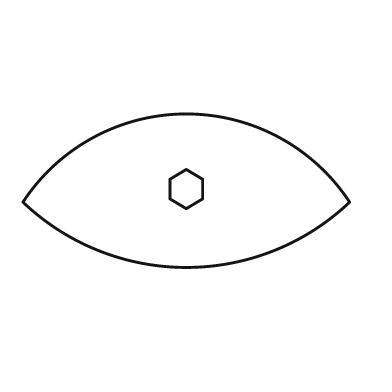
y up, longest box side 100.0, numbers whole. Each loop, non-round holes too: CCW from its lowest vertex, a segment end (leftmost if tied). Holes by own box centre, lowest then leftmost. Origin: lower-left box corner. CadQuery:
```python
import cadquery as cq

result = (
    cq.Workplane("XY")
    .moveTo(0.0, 20.0)
    .threePointArc((50.0, 0.0), (100.0, 20.0))
    .threePointArc((50.0, 47.0), (0.0, 20.0))
    .close()
    .moveTo(50.0, 18.0)
    .lineTo(55.0, 21.0)
    .lineTo(55.0, 27.0)
    .lineTo(50.0, 30.0)
    .lineTo(45.0, 27.0)
    .lineTo(45.0, 21.0)
    .close()
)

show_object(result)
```